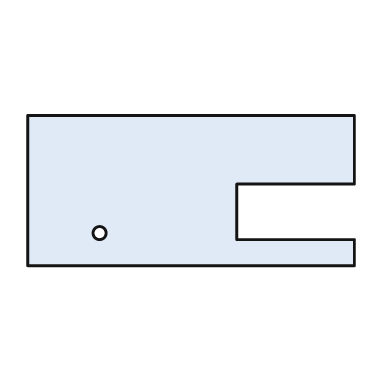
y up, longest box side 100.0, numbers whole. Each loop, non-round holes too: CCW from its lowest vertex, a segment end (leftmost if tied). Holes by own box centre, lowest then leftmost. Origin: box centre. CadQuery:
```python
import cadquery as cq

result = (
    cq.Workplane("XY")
    .moveTo(-50.0, -23.0)
    .lineTo(50.0, -23.0)
    .lineTo(50.0, -15.0)
    .lineTo(14.0, -15.0)
    .lineTo(14.0, 2.0)
    .lineTo(50.0, 2.0)
    .lineTo(50.0, 23.0)
    .lineTo(-50.0, 23.0)
    .close()
    .moveTo(-28.0, -13.0)
    .circle(2.0)
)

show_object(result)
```